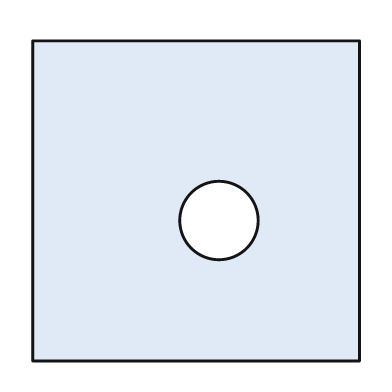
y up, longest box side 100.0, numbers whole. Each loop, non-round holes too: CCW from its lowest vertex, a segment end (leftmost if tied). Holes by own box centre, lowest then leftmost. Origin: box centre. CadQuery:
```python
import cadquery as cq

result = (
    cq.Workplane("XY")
    .moveTo(-50.0, -49.0)
    .lineTo(50.0, -49.0)
    .lineTo(50.0, 49.0)
    .lineTo(-50.0, 49.0)
    .close()
    .moveTo(7.0, -6.0)
    .circle(12.0)
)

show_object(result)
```